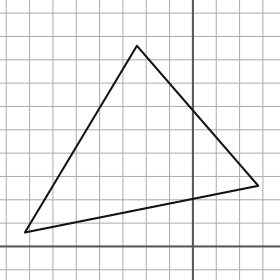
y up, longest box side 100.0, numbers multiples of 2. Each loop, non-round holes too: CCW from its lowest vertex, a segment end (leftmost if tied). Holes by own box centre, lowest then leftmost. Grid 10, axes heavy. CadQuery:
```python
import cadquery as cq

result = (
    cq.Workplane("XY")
    .moveTo(-72.0, 6.0)
    .lineTo(28.0, 26.0)
    .lineTo(-24.0, 86.0)
    .close()
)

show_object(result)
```